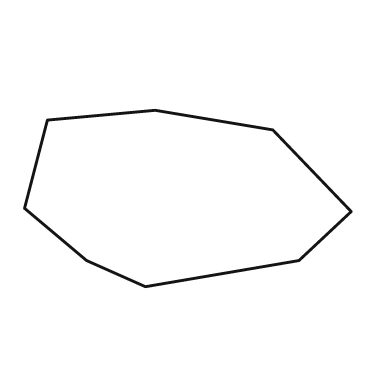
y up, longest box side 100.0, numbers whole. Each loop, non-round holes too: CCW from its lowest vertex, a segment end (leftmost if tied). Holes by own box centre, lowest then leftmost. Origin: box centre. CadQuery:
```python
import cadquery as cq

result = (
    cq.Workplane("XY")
    .moveTo(-13.0, -27.0)
    .lineTo(34.0, -19.0)
    .lineTo(50.0, -4.0)
    .lineTo(26.0, 21.0)
    .lineTo(-10.0, 27.0)
    .lineTo(-43.0, 24.0)
    .lineTo(-50.0, -3.0)
    .lineTo(-31.0, -19.0)
    .close()
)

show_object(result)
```